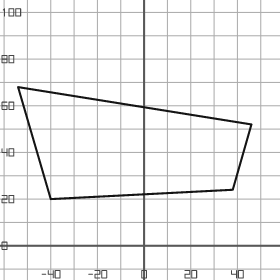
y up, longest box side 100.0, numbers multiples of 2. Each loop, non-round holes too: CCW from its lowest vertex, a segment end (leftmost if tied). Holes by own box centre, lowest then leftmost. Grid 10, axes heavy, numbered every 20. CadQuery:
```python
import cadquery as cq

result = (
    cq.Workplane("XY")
    .moveTo(-40.0, 20.0)
    .lineTo(38.0, 24.0)
    .lineTo(46.0, 52.0)
    .lineTo(-54.0, 68.0)
    .close()
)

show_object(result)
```